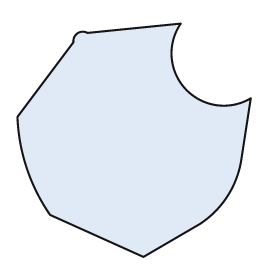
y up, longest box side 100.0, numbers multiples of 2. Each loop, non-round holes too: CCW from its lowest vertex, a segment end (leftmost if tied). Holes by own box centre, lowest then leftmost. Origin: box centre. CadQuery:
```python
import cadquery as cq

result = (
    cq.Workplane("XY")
    .moveTo(4.0, -50.0)
    .lineTo(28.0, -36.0)
    .threePointArc((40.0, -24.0), (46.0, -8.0))
    .lineTo(50.0, 18.0)
    .threePointArc((22.0, 22.0), (20.0, 50.0))
    .lineTo(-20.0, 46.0)
    .threePointArc((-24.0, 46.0), (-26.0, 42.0))
    .lineTo(-50.0, 10.0)
    .threePointArc((-46.0, -12.0), (-36.0, -32.0))
    .close()
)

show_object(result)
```